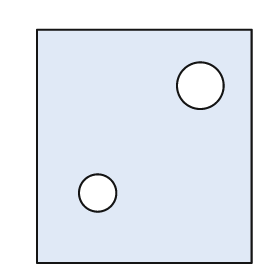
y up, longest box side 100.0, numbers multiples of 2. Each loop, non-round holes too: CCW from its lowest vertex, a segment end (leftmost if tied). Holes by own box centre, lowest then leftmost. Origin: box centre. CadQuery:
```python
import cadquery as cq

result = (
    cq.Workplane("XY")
    .moveTo(-46.0, -50.0)
    .lineTo(46.0, -50.0)
    .lineTo(46.0, 50.0)
    .lineTo(-46.0, 50.0)
    .close()
    .moveTo(-20.0, -20.0)
    .circle(8.0)
    .moveTo(24.0, 26.0)
    .circle(10.0)
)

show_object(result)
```